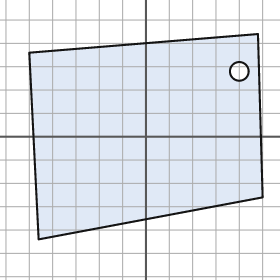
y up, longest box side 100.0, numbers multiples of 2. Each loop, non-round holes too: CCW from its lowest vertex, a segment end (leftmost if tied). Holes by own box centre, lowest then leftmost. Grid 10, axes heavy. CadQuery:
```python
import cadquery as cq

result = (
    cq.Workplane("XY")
    .moveTo(-46.0, -44.0)
    .lineTo(50.0, -26.0)
    .lineTo(48.0, 44.0)
    .lineTo(-50.0, 36.0)
    .close()
    .moveTo(40.0, 28.0)
    .circle(4.0)
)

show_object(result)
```